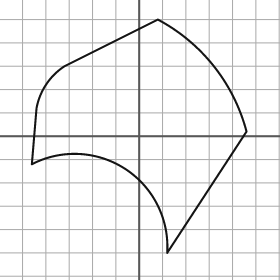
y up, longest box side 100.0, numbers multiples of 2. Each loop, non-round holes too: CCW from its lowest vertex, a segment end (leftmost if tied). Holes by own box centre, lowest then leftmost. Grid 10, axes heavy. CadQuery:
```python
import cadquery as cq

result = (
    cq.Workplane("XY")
    .moveTo(12.0, -50.0)
    .lineTo(46.0, 2.0)
    .threePointArc((32.0, 30.0), (8.0, 50.0))
    .lineTo(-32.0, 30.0)
    .threePointArc((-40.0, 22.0), (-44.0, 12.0))
    .lineTo(-46.0, -12.0)
    .threePointArc((-6.0, -14.0), (12.0, -50.0))
    .close()
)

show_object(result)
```